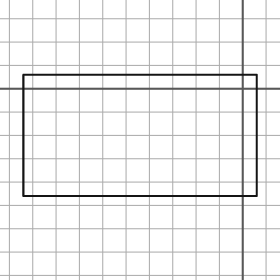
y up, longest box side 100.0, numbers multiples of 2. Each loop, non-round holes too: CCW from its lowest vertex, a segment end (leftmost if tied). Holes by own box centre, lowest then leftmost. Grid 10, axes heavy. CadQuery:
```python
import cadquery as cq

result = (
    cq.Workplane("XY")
    .moveTo(-94.0, -46.0)
    .lineTo(6.0, -46.0)
    .lineTo(6.0, 6.0)
    .lineTo(-94.0, 6.0)
    .close()
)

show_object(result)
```